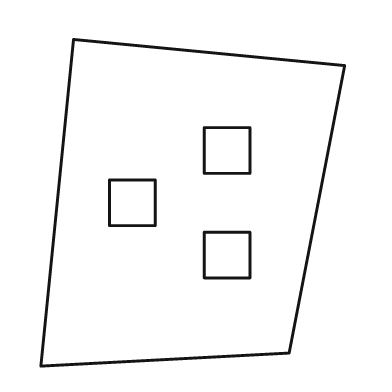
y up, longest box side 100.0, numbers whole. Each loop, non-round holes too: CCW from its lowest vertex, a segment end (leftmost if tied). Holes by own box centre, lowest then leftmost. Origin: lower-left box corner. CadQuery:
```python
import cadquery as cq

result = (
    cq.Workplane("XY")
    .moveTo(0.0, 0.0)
    .lineTo(76.0, 4.0)
    .lineTo(93.0, 92.0)
    .lineTo(10.0, 100.0)
    .close()
    .moveTo(50.0, 27.0)
    .lineTo(64.0, 27.0)
    .lineTo(64.0, 41.0)
    .lineTo(50.0, 41.0)
    .close()
    .moveTo(21.0, 43.0)
    .lineTo(35.0, 43.0)
    .lineTo(35.0, 57.0)
    .lineTo(21.0, 57.0)
    .close()
    .moveTo(50.0, 59.0)
    .lineTo(64.0, 59.0)
    .lineTo(64.0, 73.0)
    .lineTo(50.0, 73.0)
    .close()
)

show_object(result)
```